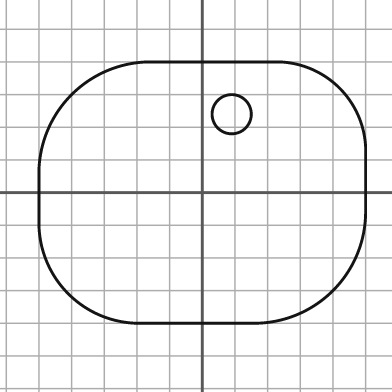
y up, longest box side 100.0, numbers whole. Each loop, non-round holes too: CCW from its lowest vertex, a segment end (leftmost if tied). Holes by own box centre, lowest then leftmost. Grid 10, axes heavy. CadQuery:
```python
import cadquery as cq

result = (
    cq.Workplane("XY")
    .moveTo(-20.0, -40.0)
    .lineTo(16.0, -40.0)
    .threePointArc((40.0, -30.0), (50.0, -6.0))
    .lineTo(50.0, 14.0)
    .threePointArc((42.0, 32.0), (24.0, 40.0))
    .lineTo(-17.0, 40.0)
    .threePointArc((-40.0, 30.0), (-50.0, 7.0))
    .lineTo(-50.0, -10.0)
    .threePointArc((-41.0, -31.0), (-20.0, -40.0))
    .close()
    .moveTo(9.0, 24.0)
    .circle(6.0)
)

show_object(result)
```